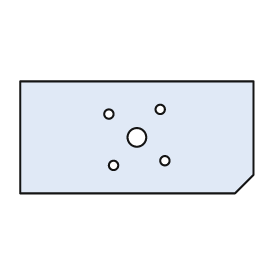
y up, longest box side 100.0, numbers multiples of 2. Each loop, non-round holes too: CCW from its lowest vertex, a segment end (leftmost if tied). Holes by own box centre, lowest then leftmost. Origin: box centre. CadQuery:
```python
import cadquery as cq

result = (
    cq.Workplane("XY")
    .moveTo(-50.0, -24.0)
    .lineTo(42.0, -24.0)
    .lineTo(50.0, -16.0)
    .lineTo(50.0, 24.0)
    .lineTo(-50.0, 24.0)
    .close()
    .moveTo(-10.0, -12.0)
    .circle(2.0)
    .moveTo(12.0, -10.0)
    .circle(2.0)
    .moveTo(0.0, 0.0)
    .circle(4.0)
    .moveTo(-12.0, 10.0)
    .circle(2.0)
    .moveTo(10.0, 12.0)
    .circle(2.0)
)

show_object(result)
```